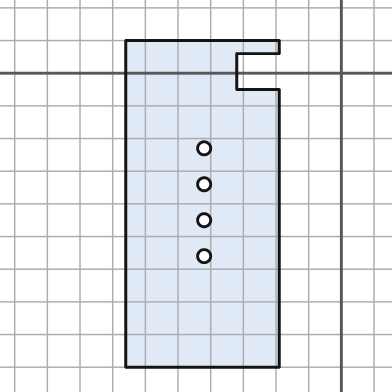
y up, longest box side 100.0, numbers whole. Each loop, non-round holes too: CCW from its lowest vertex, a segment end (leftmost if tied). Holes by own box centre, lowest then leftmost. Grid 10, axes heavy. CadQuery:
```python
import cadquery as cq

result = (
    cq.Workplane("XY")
    .moveTo(-66.0, -90.0)
    .lineTo(-19.0, -90.0)
    .lineTo(-19.0, -5.0)
    .lineTo(-32.0, -5.0)
    .lineTo(-32.0, 6.0)
    .lineTo(-19.0, 6.0)
    .lineTo(-19.0, 10.0)
    .lineTo(-66.0, 10.0)
    .close()
    .moveTo(-42.0, -56.0)
    .circle(2.0)
    .moveTo(-42.0, -45.0)
    .circle(2.0)
    .moveTo(-42.0, -34.0)
    .circle(2.0)
    .moveTo(-42.0, -23.0)
    .circle(2.0)
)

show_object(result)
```